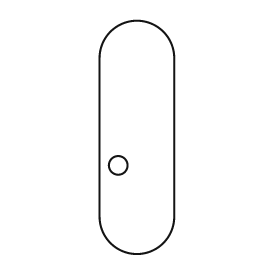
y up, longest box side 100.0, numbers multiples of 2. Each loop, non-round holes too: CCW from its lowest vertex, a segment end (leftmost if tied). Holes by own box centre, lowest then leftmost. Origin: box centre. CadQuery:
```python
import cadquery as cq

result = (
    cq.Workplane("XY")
    .moveTo(-16.0, -34.0)
    .threePointArc((0.0, -50.0), (16.0, -34.0))
    .lineTo(16.0, 34.0)
    .threePointArc((0.0, 50.0), (-16.0, 34.0))
    .close()
    .moveTo(-8.0, -12.0)
    .circle(4.0)
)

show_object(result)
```